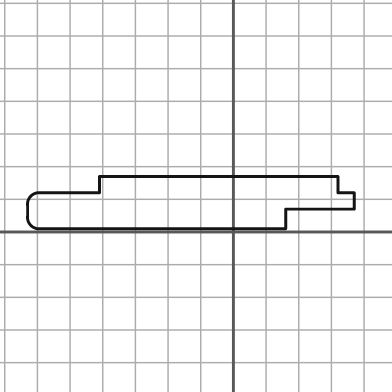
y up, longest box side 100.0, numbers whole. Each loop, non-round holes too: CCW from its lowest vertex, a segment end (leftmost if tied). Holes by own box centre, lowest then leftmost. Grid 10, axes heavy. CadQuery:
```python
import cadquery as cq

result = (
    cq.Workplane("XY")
    .moveTo(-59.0, 1.0)
    .lineTo(16.0, 1.0)
    .lineTo(16.0, 7.0)
    .lineTo(37.0, 7.0)
    .lineTo(37.0, 12.0)
    .lineTo(32.0, 12.0)
    .lineTo(32.0, 17.0)
    .lineTo(-41.0, 17.0)
    .lineTo(-41.0, 12.0)
    .lineTo(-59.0, 12.0)
    .threePointArc((-62.0, 11.0), (-63.0, 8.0))
    .lineTo(-63.0, 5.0)
    .threePointArc((-62.0, 2.0), (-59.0, 1.0))
    .close()
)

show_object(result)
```